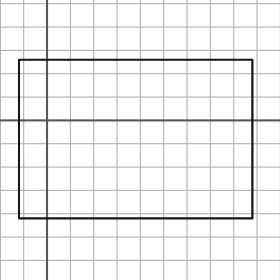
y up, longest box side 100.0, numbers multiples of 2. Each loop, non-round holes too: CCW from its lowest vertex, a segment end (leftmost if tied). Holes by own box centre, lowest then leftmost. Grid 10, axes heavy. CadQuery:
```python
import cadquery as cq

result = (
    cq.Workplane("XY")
    .moveTo(-12.0, -42.0)
    .lineTo(88.0, -42.0)
    .lineTo(88.0, 26.0)
    .lineTo(-12.0, 26.0)
    .close()
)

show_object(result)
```